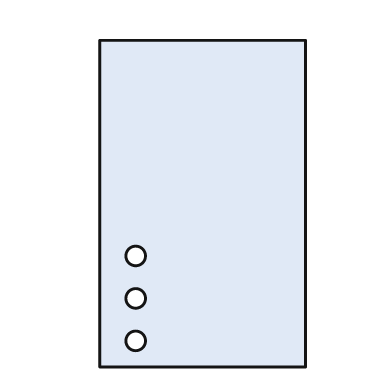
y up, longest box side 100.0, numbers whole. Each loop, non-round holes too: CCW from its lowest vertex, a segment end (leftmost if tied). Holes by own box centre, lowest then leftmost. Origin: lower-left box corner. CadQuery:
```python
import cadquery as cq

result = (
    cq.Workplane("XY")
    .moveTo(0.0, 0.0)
    .lineTo(63.0, 0.0)
    .lineTo(63.0, 100.0)
    .lineTo(0.0, 100.0)
    .close()
    .moveTo(11.0, 8.0)
    .circle(3.0)
    .moveTo(11.0, 21.0)
    .circle(3.0)
    .moveTo(11.0, 34.0)
    .circle(3.0)
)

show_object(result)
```